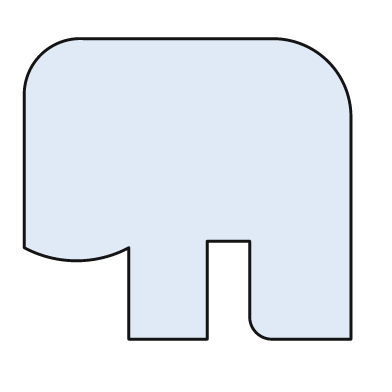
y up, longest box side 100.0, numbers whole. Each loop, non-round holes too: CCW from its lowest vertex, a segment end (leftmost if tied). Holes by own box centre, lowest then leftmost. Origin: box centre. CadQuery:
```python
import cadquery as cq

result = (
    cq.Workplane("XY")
    .moveTo(-18.0, -46.0)
    .lineTo(6.0, -46.0)
    .lineTo(6.0, -16.0)
    .lineTo(19.0, -16.0)
    .lineTo(19.0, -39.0)
    .threePointArc((21.0, -44.0), (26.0, -46.0))
    .lineTo(50.0, -46.0)
    .lineTo(50.0, 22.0)
    .threePointArc((43.0, 39.0), (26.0, 46.0))
    .lineTo(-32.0, 46.0)
    .threePointArc((-45.0, 41.0), (-50.0, 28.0))
    .lineTo(-50.0, -18.0)
    .threePointArc((-34.0, -22.0), (-18.0, -18.0))
    .close()
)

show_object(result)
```